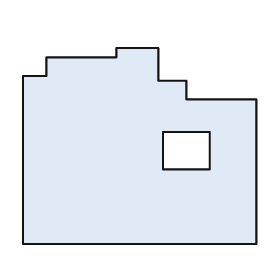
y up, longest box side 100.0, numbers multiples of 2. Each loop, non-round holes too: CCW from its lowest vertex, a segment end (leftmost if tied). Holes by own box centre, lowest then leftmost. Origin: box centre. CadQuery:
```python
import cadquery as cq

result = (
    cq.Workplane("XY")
    .moveTo(-50.0, -42.0)
    .lineTo(50.0, -42.0)
    .lineTo(50.0, 20.0)
    .lineTo(20.0, 20.0)
    .lineTo(20.0, 28.0)
    .lineTo(8.0, 28.0)
    .lineTo(8.0, 42.0)
    .lineTo(-10.0, 42.0)
    .lineTo(-10.0, 38.0)
    .lineTo(-40.0, 38.0)
    .lineTo(-40.0, 30.0)
    .lineTo(-50.0, 30.0)
    .close()
    .moveTo(10.0, -10.0)
    .lineTo(30.0, -10.0)
    .lineTo(30.0, 6.0)
    .lineTo(10.0, 6.0)
    .close()
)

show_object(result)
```